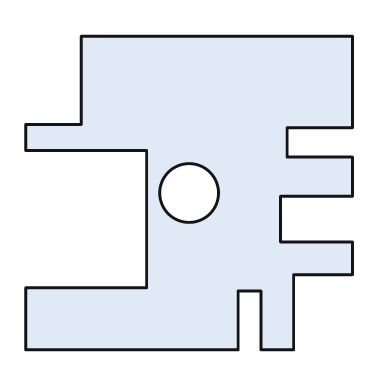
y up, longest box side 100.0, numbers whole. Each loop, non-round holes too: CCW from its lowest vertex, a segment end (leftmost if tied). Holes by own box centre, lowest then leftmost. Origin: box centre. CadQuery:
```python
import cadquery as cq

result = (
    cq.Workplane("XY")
    .moveTo(-50.0, -48.0)
    .lineTo(15.0, -48.0)
    .lineTo(15.0, -30.0)
    .lineTo(22.0, -30.0)
    .lineTo(22.0, -48.0)
    .lineTo(32.0, -48.0)
    .lineTo(32.0, -25.0)
    .lineTo(50.0, -25.0)
    .lineTo(50.0, -15.0)
    .lineTo(28.0, -15.0)
    .lineTo(28.0, -1.0)
    .lineTo(50.0, -1.0)
    .lineTo(50.0, 11.0)
    .lineTo(30.0, 11.0)
    .lineTo(30.0, 20.0)
    .lineTo(50.0, 20.0)
    .lineTo(50.0, 48.0)
    .lineTo(-33.0, 48.0)
    .lineTo(-33.0, 21.0)
    .lineTo(-50.0, 21.0)
    .lineTo(-50.0, 13.0)
    .lineTo(-13.0, 13.0)
    .lineTo(-13.0, -29.0)
    .lineTo(-50.0, -29.0)
    .close()
    .moveTo(0.0, 0.0)
    .circle(9.0)
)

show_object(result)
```